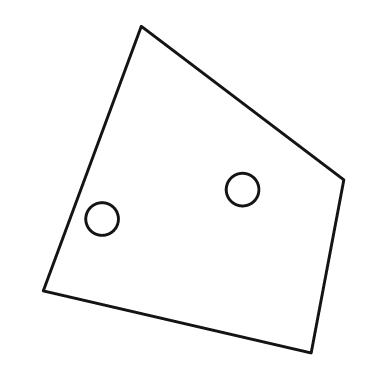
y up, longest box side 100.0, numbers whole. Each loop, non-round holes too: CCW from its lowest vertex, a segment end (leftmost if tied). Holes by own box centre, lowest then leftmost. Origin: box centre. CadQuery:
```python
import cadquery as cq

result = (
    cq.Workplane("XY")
    .moveTo(36.0, -50.0)
    .lineTo(46.0, 3.0)
    .lineTo(-16.0, 50.0)
    .lineTo(-46.0, -31.0)
    .close()
    .moveTo(-28.0, -9.0)
    .circle(5.0)
    .moveTo(15.0, 0.0)
    .circle(5.0)
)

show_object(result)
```